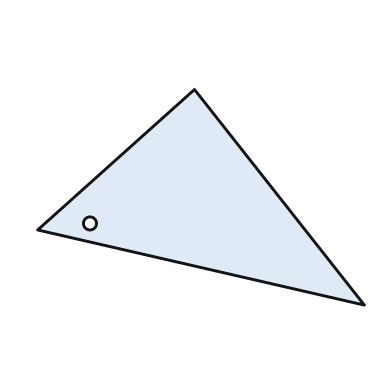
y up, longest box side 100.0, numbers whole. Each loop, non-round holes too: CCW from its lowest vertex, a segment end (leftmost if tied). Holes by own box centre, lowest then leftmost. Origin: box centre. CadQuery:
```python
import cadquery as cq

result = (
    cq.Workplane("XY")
    .moveTo(50.0, -33.0)
    .lineTo(-2.0, 33.0)
    .lineTo(-50.0, -10.0)
    .close()
    .moveTo(-34.0, -8.0)
    .circle(2.0)
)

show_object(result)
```